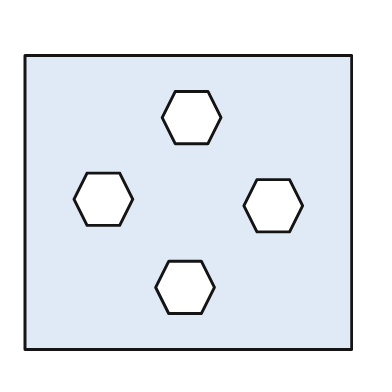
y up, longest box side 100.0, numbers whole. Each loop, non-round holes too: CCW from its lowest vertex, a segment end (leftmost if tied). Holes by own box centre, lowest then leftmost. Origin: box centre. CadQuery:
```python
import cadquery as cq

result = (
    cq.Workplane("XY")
    .moveTo(-50.0, -45.0)
    .lineTo(50.0, -45.0)
    .lineTo(50.0, 45.0)
    .lineTo(-50.0, 45.0)
    .close()
    .moveTo(-6.0, -34.0)
    .lineTo(4.0, -34.0)
    .lineTo(8.0, -26.0)
    .lineTo(4.0, -18.0)
    .lineTo(-6.0, -18.0)
    .lineTo(-10.0, -26.0)
    .close()
    .moveTo(21.0, -9.0)
    .lineTo(31.0, -9.0)
    .lineTo(35.0, -1.0)
    .lineTo(31.0, 7.0)
    .lineTo(21.0, 7.0)
    .lineTo(17.0, -1.0)
    .close()
    .moveTo(-31.0, -7.0)
    .lineTo(-21.0, -7.0)
    .lineTo(-17.0, 1.0)
    .lineTo(-21.0, 9.0)
    .lineTo(-31.0, 9.0)
    .lineTo(-35.0, 1.0)
    .close()
    .moveTo(-4.0, 18.0)
    .lineTo(6.0, 18.0)
    .lineTo(10.0, 26.0)
    .lineTo(6.0, 34.0)
    .lineTo(-4.0, 34.0)
    .lineTo(-8.0, 26.0)
    .close()
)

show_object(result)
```